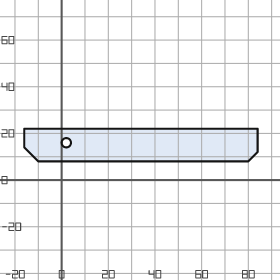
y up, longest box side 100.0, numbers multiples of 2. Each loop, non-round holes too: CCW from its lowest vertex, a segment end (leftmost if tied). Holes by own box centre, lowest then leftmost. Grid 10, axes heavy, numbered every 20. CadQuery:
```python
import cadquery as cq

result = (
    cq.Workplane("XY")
    .moveTo(-10.0, 8.0)
    .lineTo(80.0, 8.0)
    .lineTo(84.0, 12.0)
    .lineTo(84.0, 22.0)
    .lineTo(-16.0, 22.0)
    .lineTo(-16.0, 14.0)
    .close()
    .moveTo(2.0, 16.0)
    .circle(2.0)
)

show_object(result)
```